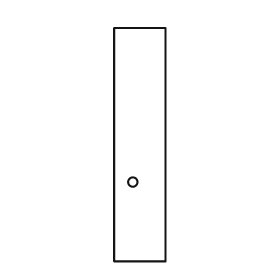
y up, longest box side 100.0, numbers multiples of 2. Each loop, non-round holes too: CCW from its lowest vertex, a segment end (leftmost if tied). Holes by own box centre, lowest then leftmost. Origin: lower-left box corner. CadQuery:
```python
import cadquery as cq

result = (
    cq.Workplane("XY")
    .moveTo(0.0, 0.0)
    .lineTo(22.0, 0.0)
    .lineTo(22.0, 100.0)
    .lineTo(0.0, 100.0)
    .close()
    .moveTo(8.0, 34.0)
    .circle(2.0)
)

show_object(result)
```